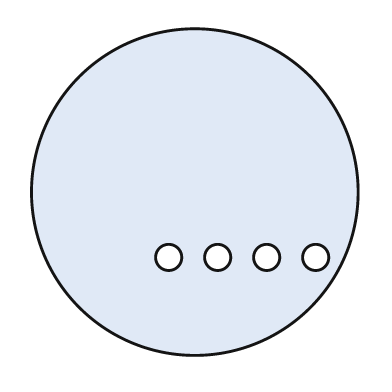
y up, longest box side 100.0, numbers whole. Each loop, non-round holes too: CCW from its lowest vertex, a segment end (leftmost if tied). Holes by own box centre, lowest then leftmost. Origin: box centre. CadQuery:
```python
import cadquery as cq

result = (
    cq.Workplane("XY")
    .moveTo(0.0, 0.0)
    .circle(50.0)
    .moveTo(-8.0, -20.0)
    .circle(4.0)
    .moveTo(7.0, -20.0)
    .circle(4.0)
    .moveTo(22.0, -20.0)
    .circle(4.0)
    .moveTo(37.0, -20.0)
    .circle(4.0)
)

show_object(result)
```